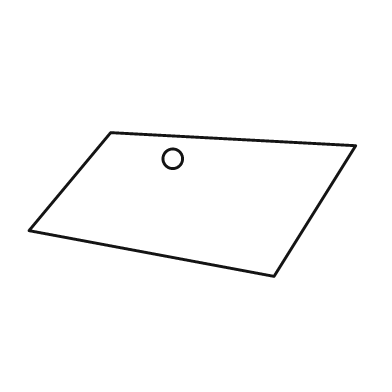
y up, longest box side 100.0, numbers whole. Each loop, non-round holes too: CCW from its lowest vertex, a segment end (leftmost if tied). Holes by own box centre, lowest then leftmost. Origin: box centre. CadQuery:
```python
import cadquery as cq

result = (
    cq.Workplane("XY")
    .moveTo(25.0, -22.0)
    .lineTo(50.0, 18.0)
    .lineTo(-25.0, 22.0)
    .lineTo(-50.0, -8.0)
    .close()
    .moveTo(-6.0, 14.0)
    .circle(3.0)
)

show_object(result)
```